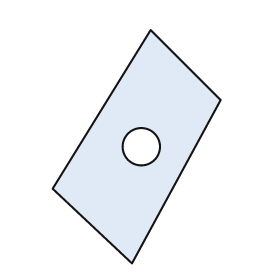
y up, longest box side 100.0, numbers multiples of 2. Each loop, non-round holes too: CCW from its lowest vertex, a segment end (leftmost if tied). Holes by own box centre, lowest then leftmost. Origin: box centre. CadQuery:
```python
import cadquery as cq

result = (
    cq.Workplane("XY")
    .moveTo(-2.0, -50.0)
    .lineTo(36.0, 20.0)
    .lineTo(6.0, 50.0)
    .lineTo(-36.0, -18.0)
    .close()
    .moveTo(2.0, 0.0)
    .circle(8.0)
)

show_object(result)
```